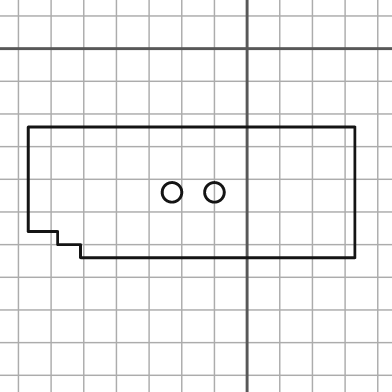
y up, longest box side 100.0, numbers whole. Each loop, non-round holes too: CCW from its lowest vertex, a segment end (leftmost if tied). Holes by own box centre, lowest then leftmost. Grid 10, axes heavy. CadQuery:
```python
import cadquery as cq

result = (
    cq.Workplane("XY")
    .moveTo(-51.0, -64.0)
    .lineTo(33.0, -64.0)
    .lineTo(33.0, -24.0)
    .lineTo(-67.0, -24.0)
    .lineTo(-67.0, -56.0)
    .lineTo(-58.0, -56.0)
    .lineTo(-58.0, -60.0)
    .lineTo(-51.0, -60.0)
    .close()
    .moveTo(-23.0, -44.0)
    .circle(3.0)
    .moveTo(-10.0, -44.0)
    .circle(3.0)
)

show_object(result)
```